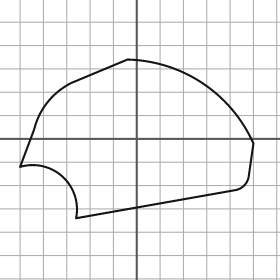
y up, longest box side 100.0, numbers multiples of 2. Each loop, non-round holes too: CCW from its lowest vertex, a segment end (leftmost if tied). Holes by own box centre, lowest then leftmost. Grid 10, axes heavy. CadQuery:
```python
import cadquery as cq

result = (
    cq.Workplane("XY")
    .moveTo(-26.0, -34.0)
    .lineTo(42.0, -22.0)
    .threePointArc((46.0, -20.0), (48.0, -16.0))
    .lineTo(50.0, -2.0)
    .threePointArc((28.0, 24.0), (-4.0, 34.0))
    .lineTo(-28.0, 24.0)
    .threePointArc((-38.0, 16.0), (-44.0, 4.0))
    .lineTo(-50.0, -12.0)
    .threePointArc((-32.0, -16.0), (-26.0, -34.0))
    .close()
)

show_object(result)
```